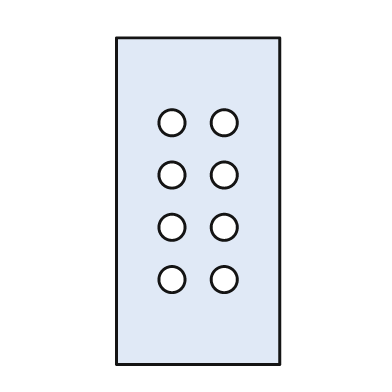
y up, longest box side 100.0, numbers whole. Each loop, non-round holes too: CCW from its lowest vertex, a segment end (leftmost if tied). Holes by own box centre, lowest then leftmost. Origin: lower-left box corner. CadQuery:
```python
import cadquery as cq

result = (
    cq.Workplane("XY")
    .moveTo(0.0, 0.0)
    .lineTo(50.0, 0.0)
    .lineTo(50.0, 100.0)
    .lineTo(0.0, 100.0)
    .close()
    .moveTo(17.0, 26.0)
    .circle(4.0)
    .moveTo(33.0, 26.0)
    .circle(4.0)
    .moveTo(17.0, 42.0)
    .circle(4.0)
    .moveTo(33.0, 42.0)
    .circle(4.0)
    .moveTo(17.0, 58.0)
    .circle(4.0)
    .moveTo(33.0, 58.0)
    .circle(4.0)
    .moveTo(17.0, 74.0)
    .circle(4.0)
    .moveTo(33.0, 74.0)
    .circle(4.0)
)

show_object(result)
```